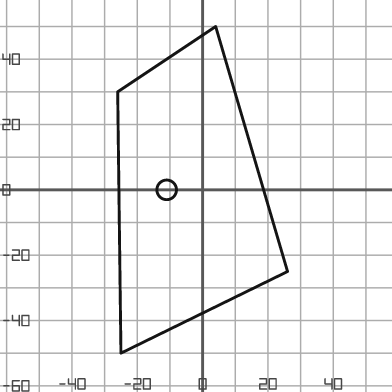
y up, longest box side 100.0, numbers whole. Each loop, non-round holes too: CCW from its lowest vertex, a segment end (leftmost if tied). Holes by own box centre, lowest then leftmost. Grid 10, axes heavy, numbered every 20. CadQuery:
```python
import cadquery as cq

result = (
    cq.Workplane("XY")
    .moveTo(-25.0, -50.0)
    .lineTo(26.0, -25.0)
    .lineTo(4.0, 50.0)
    .lineTo(-26.0, 30.0)
    .close()
    .moveTo(-11.0, 0.0)
    .circle(3.0)
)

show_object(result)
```